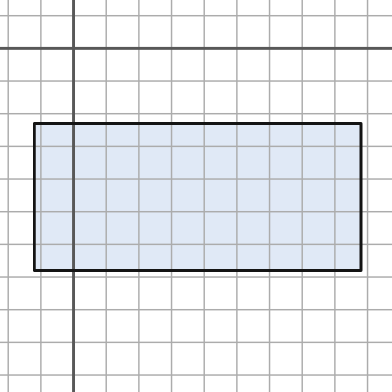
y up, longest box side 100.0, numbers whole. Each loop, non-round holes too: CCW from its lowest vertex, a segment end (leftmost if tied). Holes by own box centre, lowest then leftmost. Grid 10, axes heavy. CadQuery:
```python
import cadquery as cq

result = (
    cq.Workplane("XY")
    .moveTo(-12.0, -68.0)
    .lineTo(88.0, -68.0)
    .lineTo(88.0, -23.0)
    .lineTo(-12.0, -23.0)
    .close()
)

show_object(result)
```